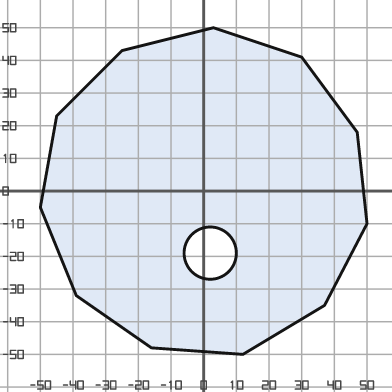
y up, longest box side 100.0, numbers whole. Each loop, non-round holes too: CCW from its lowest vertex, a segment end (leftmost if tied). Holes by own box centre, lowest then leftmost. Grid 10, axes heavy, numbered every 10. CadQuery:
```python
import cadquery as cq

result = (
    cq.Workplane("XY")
    .moveTo(12.0, -50.0)
    .lineTo(37.0, -35.0)
    .lineTo(50.0, -10.0)
    .lineTo(47.0, 18.0)
    .lineTo(30.0, 41.0)
    .lineTo(3.0, 50.0)
    .lineTo(-25.0, 43.0)
    .lineTo(-45.0, 23.0)
    .lineTo(-50.0, -5.0)
    .lineTo(-39.0, -32.0)
    .lineTo(-16.0, -48.0)
    .close()
    .moveTo(2.0, -19.0)
    .circle(8.0)
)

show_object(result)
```